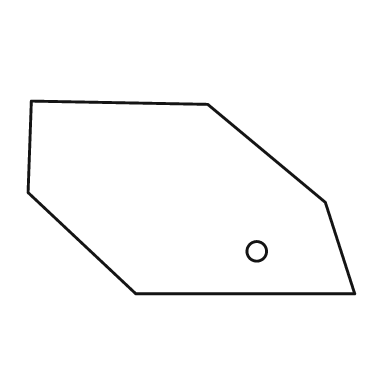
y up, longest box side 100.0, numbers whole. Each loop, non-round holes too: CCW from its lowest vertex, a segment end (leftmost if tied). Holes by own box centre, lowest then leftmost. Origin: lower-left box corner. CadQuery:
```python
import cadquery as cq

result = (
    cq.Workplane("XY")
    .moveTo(33.0, 0.0)
    .lineTo(100.0, 0.0)
    .lineTo(91.0, 28.0)
    .lineTo(55.0, 58.0)
    .lineTo(1.0, 59.0)
    .lineTo(0.0, 31.0)
    .close()
    .moveTo(70.0, 13.0)
    .circle(3.0)
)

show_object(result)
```